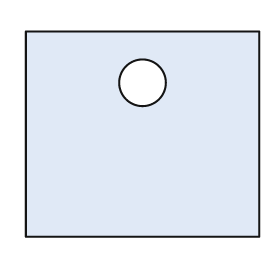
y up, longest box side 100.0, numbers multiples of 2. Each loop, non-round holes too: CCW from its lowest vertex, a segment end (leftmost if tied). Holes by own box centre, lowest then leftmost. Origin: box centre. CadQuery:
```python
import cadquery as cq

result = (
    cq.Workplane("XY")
    .moveTo(-50.0, -44.0)
    .lineTo(50.0, -44.0)
    .lineTo(50.0, 44.0)
    .lineTo(-50.0, 44.0)
    .close()
    .moveTo(0.0, 22.0)
    .circle(10.0)
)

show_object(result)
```